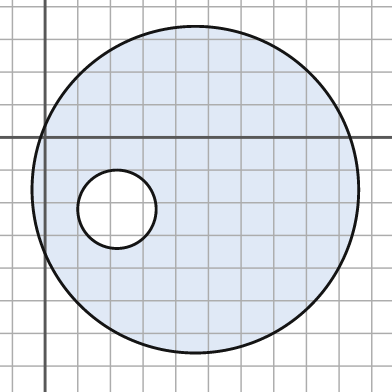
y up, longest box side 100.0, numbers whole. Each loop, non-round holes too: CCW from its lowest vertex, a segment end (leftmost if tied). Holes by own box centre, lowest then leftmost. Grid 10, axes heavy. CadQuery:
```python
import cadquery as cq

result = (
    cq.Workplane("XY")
    .moveTo(46.0, -16.0)
    .circle(50.0)
    .moveTo(22.0, -22.0)
    .circle(12.0)
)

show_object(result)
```